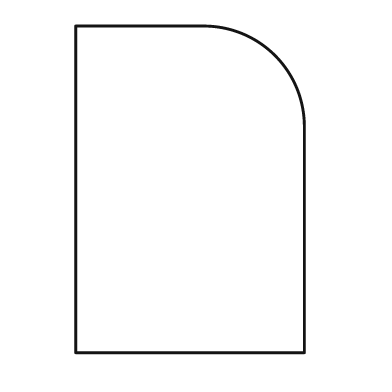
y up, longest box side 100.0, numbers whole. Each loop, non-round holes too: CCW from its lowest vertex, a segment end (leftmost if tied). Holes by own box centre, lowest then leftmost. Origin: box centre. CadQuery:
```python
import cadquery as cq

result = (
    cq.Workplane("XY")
    .moveTo(-35.0, -50.0)
    .lineTo(35.0, -50.0)
    .lineTo(35.0, 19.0)
    .threePointArc((26.0, 41.0), (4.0, 50.0))
    .lineTo(-35.0, 50.0)
    .close()
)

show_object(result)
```